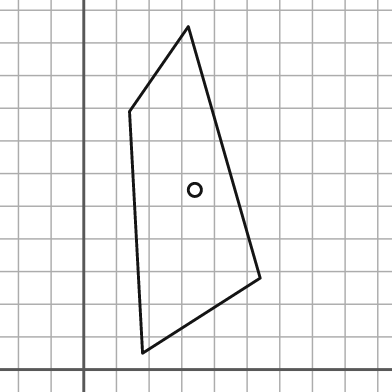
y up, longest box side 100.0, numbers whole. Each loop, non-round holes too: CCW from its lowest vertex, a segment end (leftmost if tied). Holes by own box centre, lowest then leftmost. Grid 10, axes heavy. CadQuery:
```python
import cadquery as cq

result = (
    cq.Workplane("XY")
    .moveTo(18.0, 5.0)
    .lineTo(54.0, 28.0)
    .lineTo(32.0, 105.0)
    .lineTo(14.0, 79.0)
    .close()
    .moveTo(34.0, 55.0)
    .circle(2.0)
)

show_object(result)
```